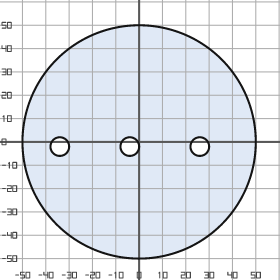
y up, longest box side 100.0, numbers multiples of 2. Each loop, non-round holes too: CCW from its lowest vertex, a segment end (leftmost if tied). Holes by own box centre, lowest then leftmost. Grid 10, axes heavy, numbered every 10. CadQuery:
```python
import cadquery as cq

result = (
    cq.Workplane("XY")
    .moveTo(0.0, 0.0)
    .circle(50.0)
    .moveTo(-34.0, -2.0)
    .circle(4.0)
    .moveTo(-4.0, -2.0)
    .circle(4.0)
    .moveTo(26.0, -2.0)
    .circle(4.0)
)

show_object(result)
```